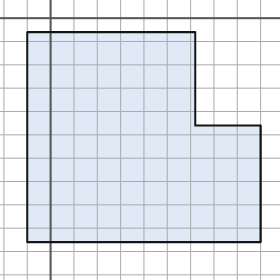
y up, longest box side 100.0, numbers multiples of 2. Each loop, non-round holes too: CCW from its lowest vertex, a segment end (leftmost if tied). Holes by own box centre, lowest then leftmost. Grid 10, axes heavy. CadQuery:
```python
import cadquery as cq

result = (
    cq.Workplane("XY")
    .moveTo(-10.0, -96.0)
    .lineTo(90.0, -96.0)
    .lineTo(90.0, -46.0)
    .lineTo(62.0, -46.0)
    .lineTo(62.0, -6.0)
    .lineTo(-10.0, -6.0)
    .close()
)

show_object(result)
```